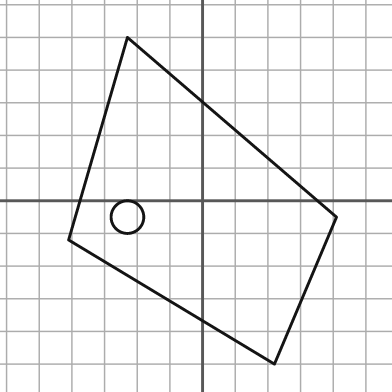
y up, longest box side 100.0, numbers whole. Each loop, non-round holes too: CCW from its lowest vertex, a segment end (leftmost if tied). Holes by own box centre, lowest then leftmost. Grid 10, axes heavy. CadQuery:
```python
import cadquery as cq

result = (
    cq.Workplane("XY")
    .moveTo(22.0, -50.0)
    .lineTo(41.0, -5.0)
    .lineTo(-23.0, 50.0)
    .lineTo(-41.0, -12.0)
    .close()
    .moveTo(-23.0, -5.0)
    .circle(5.0)
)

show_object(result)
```